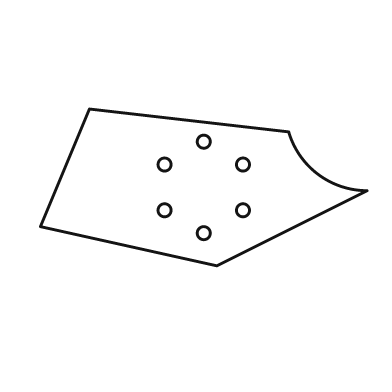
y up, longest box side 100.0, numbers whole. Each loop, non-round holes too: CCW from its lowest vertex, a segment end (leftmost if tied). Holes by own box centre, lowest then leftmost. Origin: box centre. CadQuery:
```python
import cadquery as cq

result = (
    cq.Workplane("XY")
    .moveTo(4.0, -24.0)
    .lineTo(50.0, -1.0)
    .threePointArc((35.0, 4.0), (26.0, 17.0))
    .lineTo(-35.0, 24.0)
    .lineTo(-50.0, -12.0)
    .close()
    .moveTo(0.0, -14.0)
    .circle(2.0)
    .moveTo(-12.0, -7.0)
    .circle(2.0)
    .moveTo(12.0, -7.0)
    .circle(2.0)
    .moveTo(-12.0, 7.0)
    .circle(2.0)
    .moveTo(12.0, 7.0)
    .circle(2.0)
    .moveTo(0.0, 14.0)
    .circle(2.0)
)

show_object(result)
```